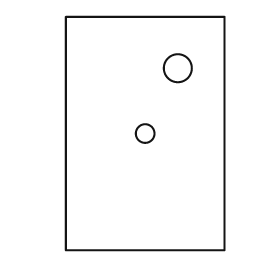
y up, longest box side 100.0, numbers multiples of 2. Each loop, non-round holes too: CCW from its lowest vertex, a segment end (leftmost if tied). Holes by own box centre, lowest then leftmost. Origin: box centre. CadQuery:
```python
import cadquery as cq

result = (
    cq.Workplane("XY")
    .moveTo(-34.0, -50.0)
    .lineTo(34.0, -50.0)
    .lineTo(34.0, 50.0)
    .lineTo(-34.0, 50.0)
    .close()
    .moveTo(0.0, 0.0)
    .circle(4.0)
    .moveTo(14.0, 28.0)
    .circle(6.0)
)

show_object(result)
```